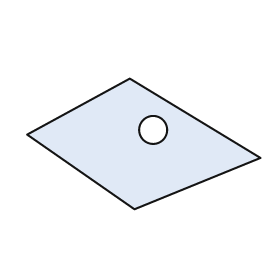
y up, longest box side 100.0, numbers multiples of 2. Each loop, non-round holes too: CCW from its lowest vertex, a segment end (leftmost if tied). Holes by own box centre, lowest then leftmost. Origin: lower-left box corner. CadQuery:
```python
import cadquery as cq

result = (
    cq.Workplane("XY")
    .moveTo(46.0, 0.0)
    .lineTo(100.0, 22.0)
    .lineTo(44.0, 56.0)
    .lineTo(0.0, 32.0)
    .close()
    .moveTo(54.0, 34.0)
    .circle(6.0)
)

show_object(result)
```